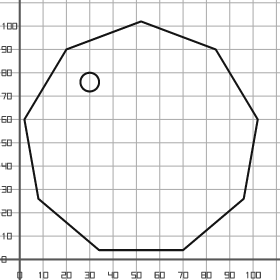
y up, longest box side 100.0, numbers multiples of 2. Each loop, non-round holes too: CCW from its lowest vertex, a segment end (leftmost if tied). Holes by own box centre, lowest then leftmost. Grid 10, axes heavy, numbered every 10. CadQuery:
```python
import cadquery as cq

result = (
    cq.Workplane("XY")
    .moveTo(34.0, 4.0)
    .lineTo(70.0, 4.0)
    .lineTo(96.0, 26.0)
    .lineTo(102.0, 60.0)
    .lineTo(84.0, 90.0)
    .lineTo(52.0, 102.0)
    .lineTo(20.0, 90.0)
    .lineTo(2.0, 60.0)
    .lineTo(8.0, 26.0)
    .close()
    .moveTo(30.0, 76.0)
    .circle(4.0)
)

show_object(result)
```